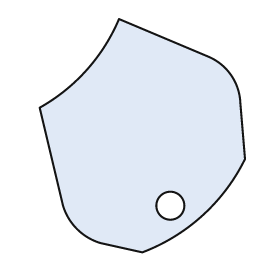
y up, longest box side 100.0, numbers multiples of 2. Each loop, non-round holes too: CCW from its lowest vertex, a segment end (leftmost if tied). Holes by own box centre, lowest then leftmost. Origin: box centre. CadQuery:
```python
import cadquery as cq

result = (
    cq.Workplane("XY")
    .moveTo(0.0, -50.0)
    .threePointArc((26.0, -34.0), (44.0, -10.0))
    .lineTo(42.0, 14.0)
    .threePointArc((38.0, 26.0), (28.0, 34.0))
    .lineTo(-10.0, 50.0)
    .threePointArc((-24.0, 28.0), (-44.0, 12.0))
    .lineTo(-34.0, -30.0)
    .threePointArc((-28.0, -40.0), (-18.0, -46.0))
    .close()
    .moveTo(12.0, -30.0)
    .circle(6.0)
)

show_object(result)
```